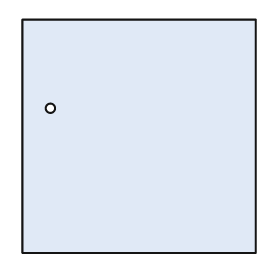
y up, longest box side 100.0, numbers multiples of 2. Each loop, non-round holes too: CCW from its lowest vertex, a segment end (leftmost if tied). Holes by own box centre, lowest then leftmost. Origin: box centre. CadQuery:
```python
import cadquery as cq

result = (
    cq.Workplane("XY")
    .moveTo(-50.0, -50.0)
    .lineTo(50.0, -50.0)
    .lineTo(50.0, 50.0)
    .lineTo(-50.0, 50.0)
    .close()
    .moveTo(-38.0, 12.0)
    .circle(2.0)
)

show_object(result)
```